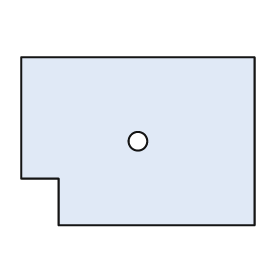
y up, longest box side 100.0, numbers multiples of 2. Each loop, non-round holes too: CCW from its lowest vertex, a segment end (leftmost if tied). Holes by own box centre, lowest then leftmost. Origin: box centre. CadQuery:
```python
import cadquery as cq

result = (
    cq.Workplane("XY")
    .moveTo(-34.0, -36.0)
    .lineTo(50.0, -36.0)
    .lineTo(50.0, 36.0)
    .lineTo(-50.0, 36.0)
    .lineTo(-50.0, -16.0)
    .lineTo(-34.0, -16.0)
    .close()
    .moveTo(0.0, 0.0)
    .circle(4.0)
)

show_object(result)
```